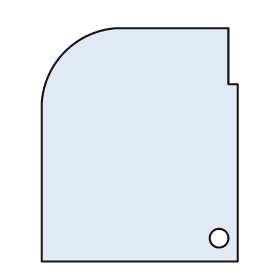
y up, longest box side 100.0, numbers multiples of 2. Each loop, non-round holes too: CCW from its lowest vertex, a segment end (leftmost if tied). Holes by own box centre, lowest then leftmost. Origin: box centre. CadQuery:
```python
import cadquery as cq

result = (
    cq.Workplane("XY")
    .moveTo(-42.0, -50.0)
    .lineTo(42.0, -50.0)
    .lineTo(42.0, 26.0)
    .lineTo(38.0, 26.0)
    .lineTo(38.0, 50.0)
    .lineTo(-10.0, 50.0)
    .threePointArc((-32.0, 40.0), (-42.0, 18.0))
    .close()
    .moveTo(34.0, -40.0)
    .circle(4.0)
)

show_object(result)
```